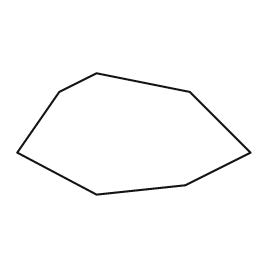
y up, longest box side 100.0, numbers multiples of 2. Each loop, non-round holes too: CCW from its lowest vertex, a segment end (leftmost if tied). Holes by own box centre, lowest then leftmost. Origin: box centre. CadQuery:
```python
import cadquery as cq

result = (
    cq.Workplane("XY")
    .moveTo(-16.0, -26.0)
    .lineTo(22.0, -22.0)
    .lineTo(50.0, -8.0)
    .lineTo(24.0, 18.0)
    .lineTo(-16.0, 26.0)
    .lineTo(-32.0, 18.0)
    .lineTo(-50.0, -8.0)
    .close()
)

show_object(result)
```